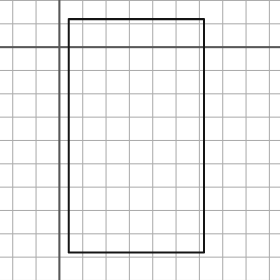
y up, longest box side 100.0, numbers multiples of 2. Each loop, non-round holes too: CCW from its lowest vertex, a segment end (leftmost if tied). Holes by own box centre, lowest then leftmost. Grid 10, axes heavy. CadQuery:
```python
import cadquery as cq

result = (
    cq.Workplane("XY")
    .moveTo(4.0, -88.0)
    .lineTo(62.0, -88.0)
    .lineTo(62.0, 12.0)
    .lineTo(4.0, 12.0)
    .close()
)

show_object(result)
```